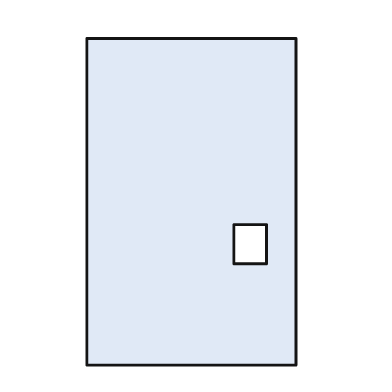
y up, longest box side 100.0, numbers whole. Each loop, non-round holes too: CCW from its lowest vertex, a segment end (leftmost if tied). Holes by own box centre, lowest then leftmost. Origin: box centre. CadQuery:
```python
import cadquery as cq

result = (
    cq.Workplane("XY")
    .moveTo(-32.0, -50.0)
    .lineTo(32.0, -50.0)
    .lineTo(32.0, 50.0)
    .lineTo(-32.0, 50.0)
    .close()
    .moveTo(13.0, -19.0)
    .lineTo(23.0, -19.0)
    .lineTo(23.0, -7.0)
    .lineTo(13.0, -7.0)
    .close()
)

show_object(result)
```